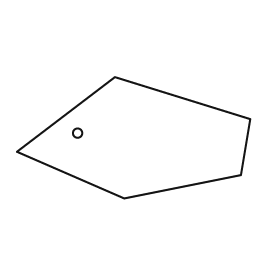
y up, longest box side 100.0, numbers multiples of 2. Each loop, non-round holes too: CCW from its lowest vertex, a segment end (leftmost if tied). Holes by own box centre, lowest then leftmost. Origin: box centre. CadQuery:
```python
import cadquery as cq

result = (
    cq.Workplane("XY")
    .moveTo(-4.0, -26.0)
    .lineTo(46.0, -16.0)
    .lineTo(50.0, 8.0)
    .lineTo(-8.0, 26.0)
    .lineTo(-50.0, -6.0)
    .close()
    .moveTo(-24.0, 2.0)
    .circle(2.0)
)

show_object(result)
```